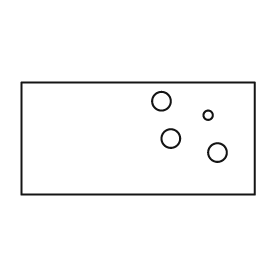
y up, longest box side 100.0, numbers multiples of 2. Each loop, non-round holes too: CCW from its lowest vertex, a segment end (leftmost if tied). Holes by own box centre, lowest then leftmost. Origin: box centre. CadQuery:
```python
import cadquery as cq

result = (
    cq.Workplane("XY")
    .moveTo(-50.0, -24.0)
    .lineTo(50.0, -24.0)
    .lineTo(50.0, 24.0)
    .lineTo(-50.0, 24.0)
    .close()
    .moveTo(34.0, -6.0)
    .circle(4.0)
    .moveTo(14.0, 0.0)
    .circle(4.0)
    .moveTo(30.0, 10.0)
    .circle(2.0)
    .moveTo(10.0, 16.0)
    .circle(4.0)
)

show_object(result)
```